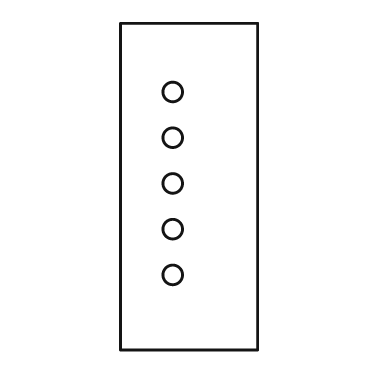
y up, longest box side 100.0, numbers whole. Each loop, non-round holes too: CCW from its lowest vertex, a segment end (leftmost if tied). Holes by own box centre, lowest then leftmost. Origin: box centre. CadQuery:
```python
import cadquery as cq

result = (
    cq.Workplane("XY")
    .moveTo(-21.0, -50.0)
    .lineTo(21.0, -50.0)
    .lineTo(21.0, 50.0)
    .lineTo(-21.0, 50.0)
    .close()
    .moveTo(-5.0, -27.0)
    .circle(3.0)
    .moveTo(-5.0, -13.0)
    .circle(3.0)
    .moveTo(-5.0, 1.0)
    .circle(3.0)
    .moveTo(-5.0, 15.0)
    .circle(3.0)
    .moveTo(-5.0, 29.0)
    .circle(3.0)
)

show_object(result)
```